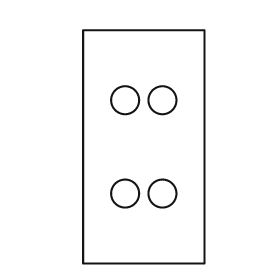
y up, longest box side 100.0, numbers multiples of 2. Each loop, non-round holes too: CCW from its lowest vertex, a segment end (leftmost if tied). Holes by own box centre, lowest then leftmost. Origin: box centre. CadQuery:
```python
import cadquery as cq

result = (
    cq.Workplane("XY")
    .moveTo(-26.0, -50.0)
    .lineTo(26.0, -50.0)
    .lineTo(26.0, 50.0)
    .lineTo(-26.0, 50.0)
    .close()
    .moveTo(-8.0, -20.0)
    .circle(6.0)
    .moveTo(8.0, -20.0)
    .circle(6.0)
    .moveTo(-8.0, 20.0)
    .circle(6.0)
    .moveTo(8.0, 20.0)
    .circle(6.0)
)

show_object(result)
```